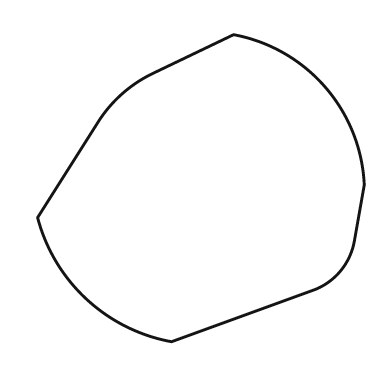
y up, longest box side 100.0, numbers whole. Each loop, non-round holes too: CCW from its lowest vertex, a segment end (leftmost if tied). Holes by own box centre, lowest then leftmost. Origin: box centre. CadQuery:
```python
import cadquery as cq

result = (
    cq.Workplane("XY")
    .moveTo(-9.0, -47.0)
    .lineTo(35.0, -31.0)
    .threePointArc((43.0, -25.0), (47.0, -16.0))
    .lineTo(50.0, 1.0)
    .threePointArc((38.0, 31.0), (10.0, 47.0))
    .lineTo(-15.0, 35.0)
    .threePointArc((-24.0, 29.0), (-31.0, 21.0))
    .lineTo(-50.0, -9.0)
    .threePointArc((-35.0, -34.0), (-9.0, -47.0))
    .close()
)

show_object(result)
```